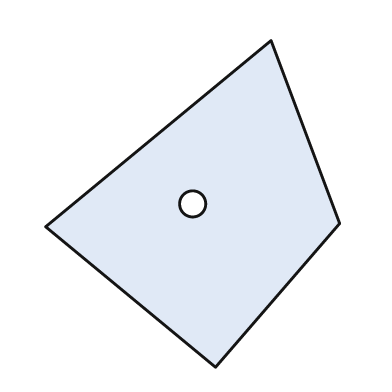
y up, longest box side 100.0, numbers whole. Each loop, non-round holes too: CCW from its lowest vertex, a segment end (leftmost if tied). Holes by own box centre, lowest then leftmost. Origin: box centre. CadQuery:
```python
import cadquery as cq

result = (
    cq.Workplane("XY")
    .moveTo(7.0, -50.0)
    .lineTo(45.0, -6.0)
    .lineTo(24.0, 50.0)
    .lineTo(-45.0, -7.0)
    .close()
    .moveTo(0.0, 0.0)
    .circle(4.0)
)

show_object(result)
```